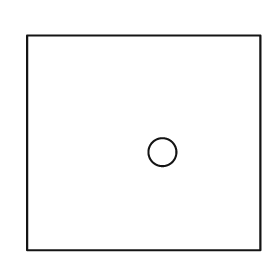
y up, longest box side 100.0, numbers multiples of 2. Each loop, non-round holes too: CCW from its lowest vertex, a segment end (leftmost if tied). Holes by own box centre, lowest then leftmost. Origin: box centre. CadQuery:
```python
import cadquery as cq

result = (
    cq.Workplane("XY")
    .moveTo(-50.0, -46.0)
    .lineTo(50.0, -46.0)
    .lineTo(50.0, 46.0)
    .lineTo(-50.0, 46.0)
    .close()
    .moveTo(8.0, -4.0)
    .circle(6.0)
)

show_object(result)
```